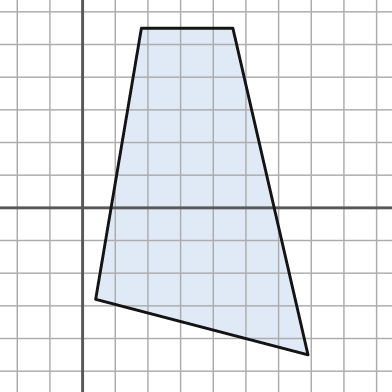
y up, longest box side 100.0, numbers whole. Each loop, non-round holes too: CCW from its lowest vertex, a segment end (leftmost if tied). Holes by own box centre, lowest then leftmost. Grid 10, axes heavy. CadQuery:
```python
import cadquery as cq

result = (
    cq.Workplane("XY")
    .moveTo(69.0, -45.0)
    .lineTo(46.0, 55.0)
    .lineTo(18.0, 55.0)
    .lineTo(4.0, -28.0)
    .close()
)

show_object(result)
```